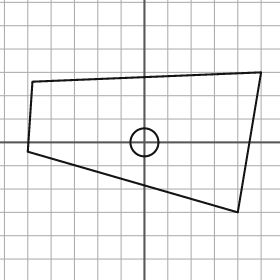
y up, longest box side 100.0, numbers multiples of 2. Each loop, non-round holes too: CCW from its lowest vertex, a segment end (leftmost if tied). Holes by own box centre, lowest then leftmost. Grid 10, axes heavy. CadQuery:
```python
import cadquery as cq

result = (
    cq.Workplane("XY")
    .moveTo(40.0, -30.0)
    .lineTo(50.0, 30.0)
    .lineTo(-48.0, 26.0)
    .lineTo(-50.0, -4.0)
    .close()
    .moveTo(0.0, 0.0)
    .circle(6.0)
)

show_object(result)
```